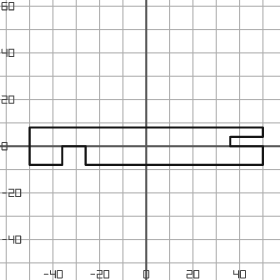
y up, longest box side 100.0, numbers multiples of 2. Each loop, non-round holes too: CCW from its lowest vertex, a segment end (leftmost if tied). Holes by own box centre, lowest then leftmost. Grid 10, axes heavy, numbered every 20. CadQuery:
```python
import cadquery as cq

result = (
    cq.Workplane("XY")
    .moveTo(-50.0, -8.0)
    .lineTo(-36.0, -8.0)
    .lineTo(-36.0, 0.0)
    .lineTo(-26.0, 0.0)
    .lineTo(-26.0, -8.0)
    .lineTo(50.0, -8.0)
    .lineTo(50.0, 0.0)
    .lineTo(36.0, 0.0)
    .lineTo(36.0, 4.0)
    .lineTo(50.0, 4.0)
    .lineTo(50.0, 8.0)
    .lineTo(-50.0, 8.0)
    .close()
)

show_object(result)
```